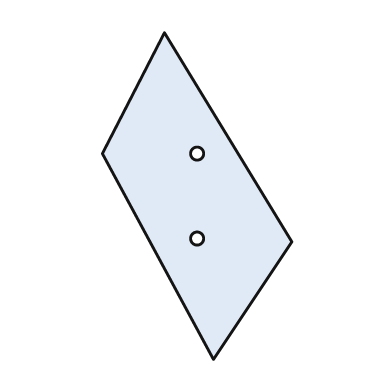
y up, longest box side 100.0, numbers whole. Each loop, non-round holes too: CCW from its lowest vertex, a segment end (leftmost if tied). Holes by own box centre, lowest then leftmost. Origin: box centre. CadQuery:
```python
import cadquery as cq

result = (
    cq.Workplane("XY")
    .moveTo(5.0, -50.0)
    .lineTo(29.0, -14.0)
    .lineTo(-10.0, 50.0)
    .lineTo(-29.0, 13.0)
    .close()
    .moveTo(0.0, -13.0)
    .circle(2.0)
    .moveTo(0.0, 13.0)
    .circle(2.0)
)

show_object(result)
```